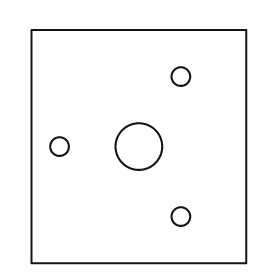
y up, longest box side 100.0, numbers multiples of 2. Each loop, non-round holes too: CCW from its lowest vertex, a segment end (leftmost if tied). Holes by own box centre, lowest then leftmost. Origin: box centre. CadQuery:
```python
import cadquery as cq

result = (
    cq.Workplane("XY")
    .moveTo(-46.0, -50.0)
    .lineTo(46.0, -50.0)
    .lineTo(46.0, 50.0)
    .lineTo(-46.0, 50.0)
    .close()
    .moveTo(18.0, -30.0)
    .circle(4.0)
    .moveTo(-34.0, 0.0)
    .circle(4.0)
    .moveTo(0.0, 0.0)
    .circle(10.0)
    .moveTo(18.0, 30.0)
    .circle(4.0)
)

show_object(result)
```